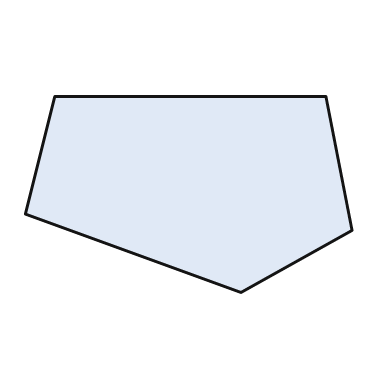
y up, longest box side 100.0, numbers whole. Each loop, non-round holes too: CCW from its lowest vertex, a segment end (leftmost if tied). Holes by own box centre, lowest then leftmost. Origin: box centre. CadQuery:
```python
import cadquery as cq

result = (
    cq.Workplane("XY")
    .moveTo(16.0, -30.0)
    .lineTo(50.0, -11.0)
    .lineTo(42.0, 30.0)
    .lineTo(-41.0, 30.0)
    .lineTo(-50.0, -6.0)
    .close()
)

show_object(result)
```